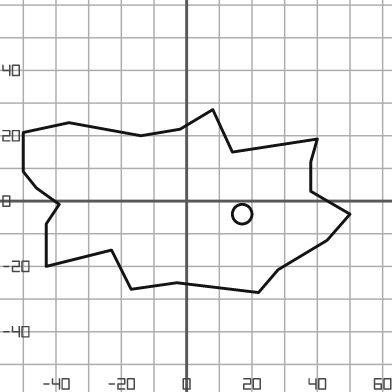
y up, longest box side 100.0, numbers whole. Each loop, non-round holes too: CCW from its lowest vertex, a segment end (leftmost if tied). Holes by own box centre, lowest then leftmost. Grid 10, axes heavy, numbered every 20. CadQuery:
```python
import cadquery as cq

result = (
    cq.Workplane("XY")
    .moveTo(22.0, -28.0)
    .lineTo(28.0, -21.0)
    .lineTo(43.0, -12.0)
    .lineTo(50.0, -4.0)
    .lineTo(38.0, 3.0)
    .lineTo(38.0, 12.0)
    .lineTo(40.0, 19.0)
    .lineTo(14.0, 15.0)
    .lineTo(8.0, 28.0)
    .lineTo(-2.0, 22.0)
    .lineTo(-14.0, 20.0)
    .lineTo(-36.0, 24.0)
    .lineTo(-50.0, 21.0)
    .lineTo(-50.0, 9.0)
    .lineTo(-46.0, 4.0)
    .lineTo(-39.0, -1.0)
    .lineTo(-43.0, -7.0)
    .lineTo(-43.0, -20.0)
    .lineTo(-23.0, -15.0)
    .lineTo(-17.0, -27.0)
    .lineTo(-3.0, -25.0)
    .close()
    .moveTo(17.0, -4.0)
    .circle(3.0)
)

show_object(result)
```